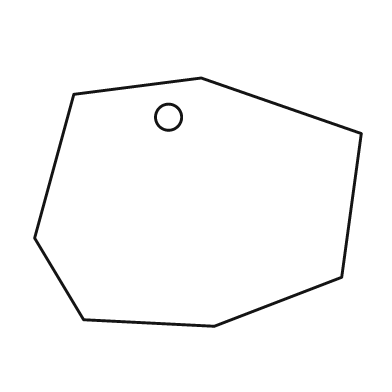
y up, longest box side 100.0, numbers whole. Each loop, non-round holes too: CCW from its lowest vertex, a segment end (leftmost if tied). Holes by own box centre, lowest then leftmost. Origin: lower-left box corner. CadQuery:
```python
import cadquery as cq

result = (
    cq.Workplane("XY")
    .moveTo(55.0, 0.0)
    .lineTo(94.0, 15.0)
    .lineTo(100.0, 59.0)
    .lineTo(51.0, 76.0)
    .lineTo(12.0, 71.0)
    .lineTo(0.0, 27.0)
    .lineTo(15.0, 2.0)
    .close()
    .moveTo(41.0, 64.0)
    .circle(4.0)
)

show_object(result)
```